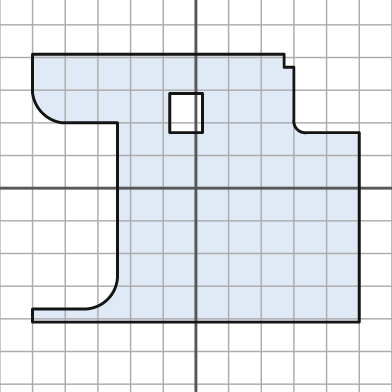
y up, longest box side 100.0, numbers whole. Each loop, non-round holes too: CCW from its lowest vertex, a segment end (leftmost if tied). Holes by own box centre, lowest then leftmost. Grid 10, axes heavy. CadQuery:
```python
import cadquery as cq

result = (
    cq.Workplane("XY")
    .moveTo(-50.0, -41.0)
    .lineTo(50.0, -41.0)
    .lineTo(50.0, 17.0)
    .lineTo(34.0, 17.0)
    .threePointArc((31.0, 18.0), (30.0, 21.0))
    .lineTo(30.0, 37.0)
    .lineTo(27.0, 37.0)
    .lineTo(27.0, 41.0)
    .lineTo(-50.0, 41.0)
    .lineTo(-50.0, 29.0)
    .threePointArc((-47.0, 23.0), (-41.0, 20.0))
    .lineTo(-24.0, 20.0)
    .lineTo(-24.0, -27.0)
    .threePointArc((-27.0, -34.0), (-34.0, -37.0))
    .lineTo(-50.0, -37.0)
    .close()
    .moveTo(-8.0, 17.0)
    .lineTo(2.0, 17.0)
    .lineTo(2.0, 29.0)
    .lineTo(-8.0, 29.0)
    .close()
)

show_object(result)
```